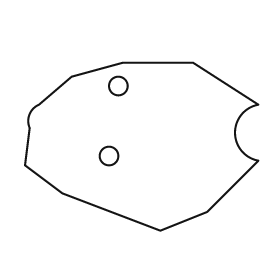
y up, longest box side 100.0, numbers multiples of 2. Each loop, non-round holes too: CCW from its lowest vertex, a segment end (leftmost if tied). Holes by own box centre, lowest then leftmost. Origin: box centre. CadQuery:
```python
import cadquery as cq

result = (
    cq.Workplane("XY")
    .moveTo(8.0, -36.0)
    .lineTo(28.0, -28.0)
    .lineTo(50.0, -6.0)
    .threePointArc((40.0, 6.0), (50.0, 18.0))
    .lineTo(22.0, 36.0)
    .lineTo(-8.0, 36.0)
    .lineTo(-30.0, 30.0)
    .lineTo(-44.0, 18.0)
    .threePointArc((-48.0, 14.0), (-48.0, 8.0))
    .lineTo(-50.0, -8.0)
    .lineTo(-34.0, -20.0)
    .close()
    .moveTo(-14.0, -4.0)
    .circle(4.0)
    .moveTo(-10.0, 26.0)
    .circle(4.0)
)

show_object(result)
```